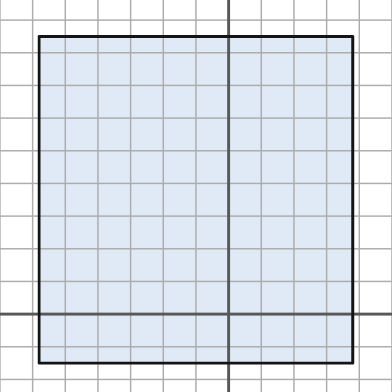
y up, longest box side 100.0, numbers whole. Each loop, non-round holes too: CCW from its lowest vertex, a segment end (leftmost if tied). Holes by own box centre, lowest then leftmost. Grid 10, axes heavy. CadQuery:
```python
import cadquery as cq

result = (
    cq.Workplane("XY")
    .moveTo(-58.0, -15.0)
    .lineTo(38.0, -15.0)
    .lineTo(38.0, 85.0)
    .lineTo(-58.0, 85.0)
    .close()
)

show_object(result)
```